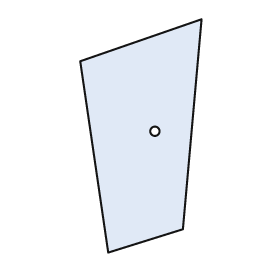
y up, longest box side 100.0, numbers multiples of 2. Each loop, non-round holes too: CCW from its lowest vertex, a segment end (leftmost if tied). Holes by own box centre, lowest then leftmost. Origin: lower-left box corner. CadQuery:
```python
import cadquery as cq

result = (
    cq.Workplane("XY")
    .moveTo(12.0, 0.0)
    .lineTo(44.0, 10.0)
    .lineTo(52.0, 100.0)
    .lineTo(0.0, 82.0)
    .close()
    .moveTo(32.0, 52.0)
    .circle(2.0)
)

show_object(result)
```